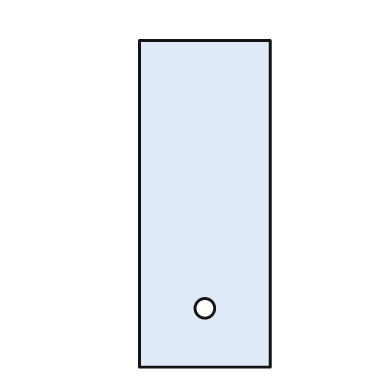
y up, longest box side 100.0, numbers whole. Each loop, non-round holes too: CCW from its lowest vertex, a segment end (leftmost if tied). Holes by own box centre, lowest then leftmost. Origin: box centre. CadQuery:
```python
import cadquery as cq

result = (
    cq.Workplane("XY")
    .moveTo(-20.0, -50.0)
    .lineTo(20.0, -50.0)
    .lineTo(20.0, 50.0)
    .lineTo(-20.0, 50.0)
    .close()
    .moveTo(0.0, -32.0)
    .circle(3.0)
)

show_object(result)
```